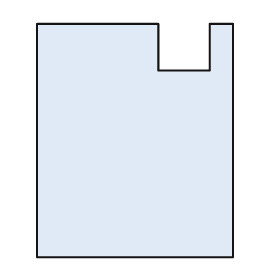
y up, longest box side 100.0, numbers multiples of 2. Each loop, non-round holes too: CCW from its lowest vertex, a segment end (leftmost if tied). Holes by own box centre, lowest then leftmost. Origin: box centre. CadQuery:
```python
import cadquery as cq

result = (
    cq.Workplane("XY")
    .moveTo(-42.0, -50.0)
    .lineTo(42.0, -50.0)
    .lineTo(42.0, 50.0)
    .lineTo(32.0, 50.0)
    .lineTo(32.0, 30.0)
    .lineTo(10.0, 30.0)
    .lineTo(10.0, 50.0)
    .lineTo(-42.0, 50.0)
    .close()
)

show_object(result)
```